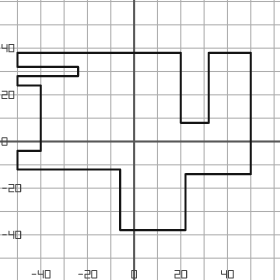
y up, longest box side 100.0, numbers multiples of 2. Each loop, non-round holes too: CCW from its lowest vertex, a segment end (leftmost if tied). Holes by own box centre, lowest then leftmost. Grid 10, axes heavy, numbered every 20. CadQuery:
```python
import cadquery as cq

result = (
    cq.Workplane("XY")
    .moveTo(-6.0, -38.0)
    .lineTo(22.0, -38.0)
    .lineTo(22.0, -14.0)
    .lineTo(50.0, -14.0)
    .lineTo(50.0, 38.0)
    .lineTo(32.0, 38.0)
    .lineTo(32.0, 8.0)
    .lineTo(20.0, 8.0)
    .lineTo(20.0, 38.0)
    .lineTo(-50.0, 38.0)
    .lineTo(-50.0, 32.0)
    .lineTo(-24.0, 32.0)
    .lineTo(-24.0, 28.0)
    .lineTo(-50.0, 28.0)
    .lineTo(-50.0, 24.0)
    .lineTo(-40.0, 24.0)
    .lineTo(-40.0, -4.0)
    .lineTo(-50.0, -4.0)
    .lineTo(-50.0, -12.0)
    .lineTo(-6.0, -12.0)
    .close()
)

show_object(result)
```